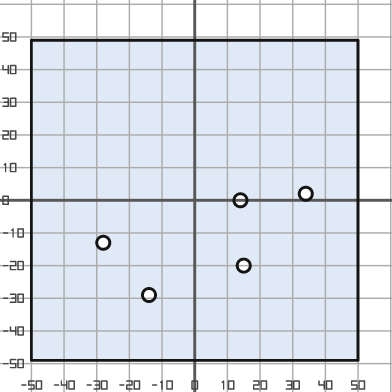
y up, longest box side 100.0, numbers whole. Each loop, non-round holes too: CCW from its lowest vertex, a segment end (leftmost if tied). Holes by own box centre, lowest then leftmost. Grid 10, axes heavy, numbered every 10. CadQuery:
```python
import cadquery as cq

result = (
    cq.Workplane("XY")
    .moveTo(-50.0, -49.0)
    .lineTo(50.0, -49.0)
    .lineTo(50.0, 49.0)
    .lineTo(-50.0, 49.0)
    .close()
    .moveTo(-14.0, -29.0)
    .circle(2.0)
    .moveTo(15.0, -20.0)
    .circle(2.0)
    .moveTo(-28.0, -13.0)
    .circle(2.0)
    .moveTo(14.0, 0.0)
    .circle(2.0)
    .moveTo(34.0, 2.0)
    .circle(2.0)
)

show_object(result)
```